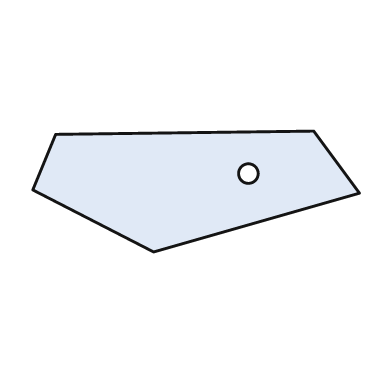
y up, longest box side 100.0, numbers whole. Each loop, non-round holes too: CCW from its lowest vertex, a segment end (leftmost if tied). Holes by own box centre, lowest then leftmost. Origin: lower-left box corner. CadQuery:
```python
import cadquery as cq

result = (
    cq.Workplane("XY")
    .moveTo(37.0, 0.0)
    .lineTo(100.0, 18.0)
    .lineTo(86.0, 37.0)
    .lineTo(7.0, 36.0)
    .lineTo(0.0, 19.0)
    .close()
    .moveTo(66.0, 24.0)
    .circle(3.0)
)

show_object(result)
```